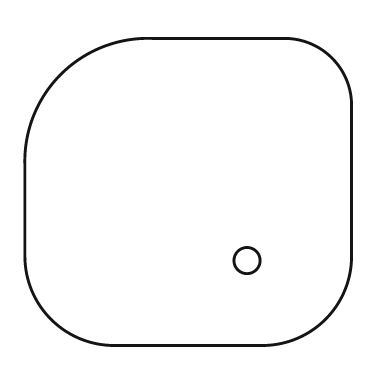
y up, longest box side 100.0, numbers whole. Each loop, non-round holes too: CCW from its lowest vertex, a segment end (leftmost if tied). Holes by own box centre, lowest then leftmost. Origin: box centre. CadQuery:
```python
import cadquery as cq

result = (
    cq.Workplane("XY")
    .moveTo(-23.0, -47.0)
    .lineTo(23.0, -47.0)
    .threePointArc((42.0, -39.0), (50.0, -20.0))
    .lineTo(50.0, 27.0)
    .threePointArc((44.0, 41.0), (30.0, 47.0))
    .lineTo(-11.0, 47.0)
    .threePointArc((-39.0, 36.0), (-50.0, 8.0))
    .lineTo(-50.0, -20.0)
    .threePointArc((-42.0, -39.0), (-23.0, -47.0))
    .close()
    .moveTo(18.0, -21.0)
    .circle(4.0)
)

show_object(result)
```